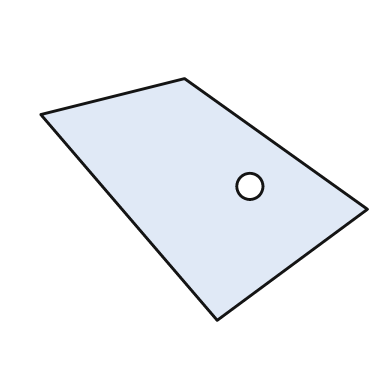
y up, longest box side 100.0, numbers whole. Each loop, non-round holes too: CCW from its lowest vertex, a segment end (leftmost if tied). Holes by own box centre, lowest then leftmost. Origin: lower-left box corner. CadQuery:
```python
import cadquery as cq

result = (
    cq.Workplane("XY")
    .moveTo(54.0, 0.0)
    .lineTo(100.0, 34.0)
    .lineTo(44.0, 74.0)
    .lineTo(0.0, 63.0)
    .close()
    .moveTo(64.0, 41.0)
    .circle(4.0)
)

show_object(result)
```